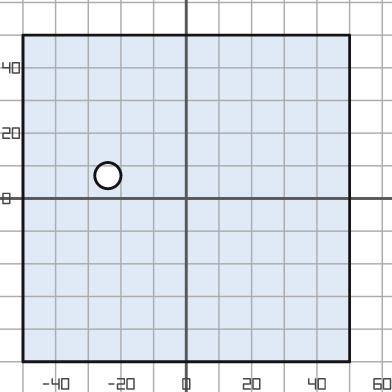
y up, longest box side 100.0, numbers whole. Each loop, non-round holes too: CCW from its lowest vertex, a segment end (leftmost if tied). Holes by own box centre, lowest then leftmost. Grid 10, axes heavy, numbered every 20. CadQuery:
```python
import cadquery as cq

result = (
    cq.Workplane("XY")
    .moveTo(-50.0, -50.0)
    .lineTo(50.0, -50.0)
    .lineTo(50.0, 50.0)
    .lineTo(-50.0, 50.0)
    .close()
    .moveTo(-24.0, 7.0)
    .circle(4.0)
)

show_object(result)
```